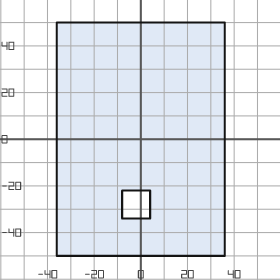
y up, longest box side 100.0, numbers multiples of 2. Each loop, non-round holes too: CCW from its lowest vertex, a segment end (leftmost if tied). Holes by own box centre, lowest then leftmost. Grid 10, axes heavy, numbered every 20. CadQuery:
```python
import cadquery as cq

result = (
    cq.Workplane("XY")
    .moveTo(-36.0, -50.0)
    .lineTo(36.0, -50.0)
    .lineTo(36.0, 50.0)
    .lineTo(-36.0, 50.0)
    .close()
    .moveTo(-8.0, -34.0)
    .lineTo(4.0, -34.0)
    .lineTo(4.0, -22.0)
    .lineTo(-8.0, -22.0)
    .close()
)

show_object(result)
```